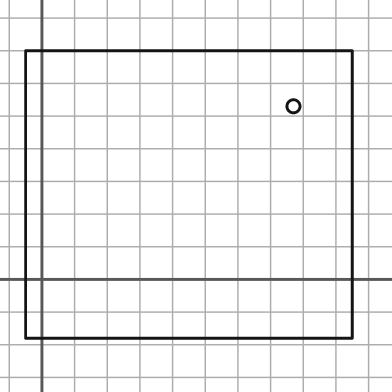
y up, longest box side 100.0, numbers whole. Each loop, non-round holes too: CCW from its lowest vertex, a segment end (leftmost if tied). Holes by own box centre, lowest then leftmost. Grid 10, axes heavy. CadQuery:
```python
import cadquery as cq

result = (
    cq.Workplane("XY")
    .moveTo(-5.0, -18.0)
    .lineTo(95.0, -18.0)
    .lineTo(95.0, 70.0)
    .lineTo(-5.0, 70.0)
    .close()
    .moveTo(77.0, 53.0)
    .circle(2.0)
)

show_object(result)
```